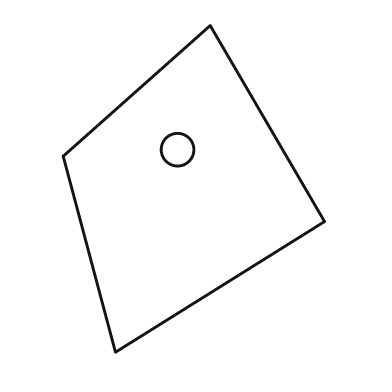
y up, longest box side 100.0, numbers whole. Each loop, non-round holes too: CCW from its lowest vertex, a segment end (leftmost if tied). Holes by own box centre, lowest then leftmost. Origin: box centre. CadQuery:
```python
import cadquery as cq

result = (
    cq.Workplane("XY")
    .moveTo(-24.0, -50.0)
    .lineTo(40.0, -10.0)
    .lineTo(5.0, 50.0)
    .lineTo(-40.0, 10.0)
    .close()
    .moveTo(-5.0, 12.0)
    .circle(5.0)
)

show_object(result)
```